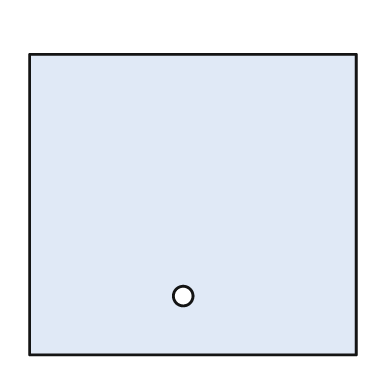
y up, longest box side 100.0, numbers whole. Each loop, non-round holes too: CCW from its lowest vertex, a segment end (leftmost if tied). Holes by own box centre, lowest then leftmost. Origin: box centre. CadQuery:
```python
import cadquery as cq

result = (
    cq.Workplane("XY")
    .moveTo(-50.0, -46.0)
    .lineTo(50.0, -46.0)
    .lineTo(50.0, 46.0)
    .lineTo(-50.0, 46.0)
    .close()
    .moveTo(-3.0, -28.0)
    .circle(3.0)
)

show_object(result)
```